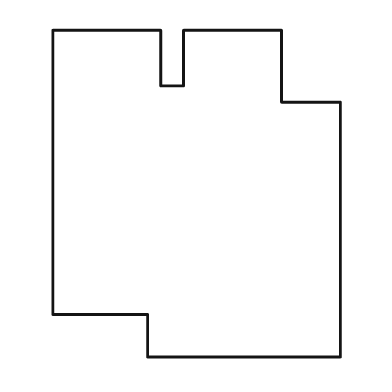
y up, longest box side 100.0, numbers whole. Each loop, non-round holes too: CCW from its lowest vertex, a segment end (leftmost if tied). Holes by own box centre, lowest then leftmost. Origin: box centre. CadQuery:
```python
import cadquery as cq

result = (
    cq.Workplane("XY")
    .moveTo(-15.0, -50.0)
    .lineTo(44.0, -50.0)
    .lineTo(44.0, 28.0)
    .lineTo(26.0, 28.0)
    .lineTo(26.0, 50.0)
    .lineTo(-4.0, 50.0)
    .lineTo(-4.0, 33.0)
    .lineTo(-11.0, 33.0)
    .lineTo(-11.0, 50.0)
    .lineTo(-44.0, 50.0)
    .lineTo(-44.0, -37.0)
    .lineTo(-15.0, -37.0)
    .close()
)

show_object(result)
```